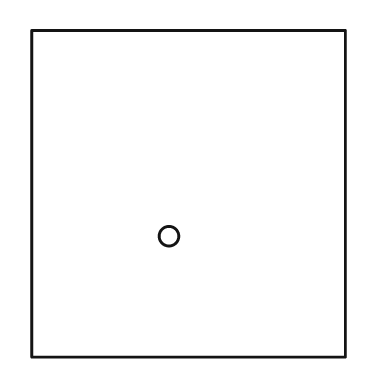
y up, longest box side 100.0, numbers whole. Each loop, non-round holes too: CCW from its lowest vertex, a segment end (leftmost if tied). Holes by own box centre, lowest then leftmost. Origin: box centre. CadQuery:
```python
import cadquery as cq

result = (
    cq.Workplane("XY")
    .moveTo(-48.0, -50.0)
    .lineTo(48.0, -50.0)
    .lineTo(48.0, 50.0)
    .lineTo(-48.0, 50.0)
    .close()
    .moveTo(-6.0, -13.0)
    .circle(3.0)
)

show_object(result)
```